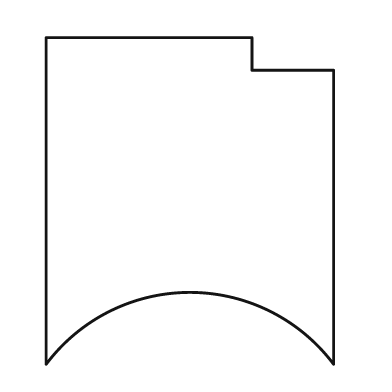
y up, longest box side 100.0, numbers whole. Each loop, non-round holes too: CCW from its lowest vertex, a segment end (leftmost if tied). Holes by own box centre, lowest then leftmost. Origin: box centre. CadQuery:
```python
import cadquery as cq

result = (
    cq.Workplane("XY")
    .moveTo(-44.0, -50.0)
    .threePointArc((0.0, -28.0), (44.0, -50.0))
    .lineTo(44.0, 40.0)
    .lineTo(19.0, 40.0)
    .lineTo(19.0, 50.0)
    .lineTo(-44.0, 50.0)
    .close()
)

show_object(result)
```